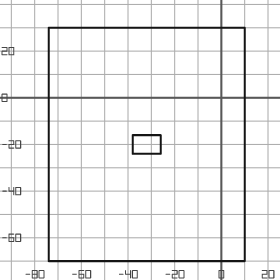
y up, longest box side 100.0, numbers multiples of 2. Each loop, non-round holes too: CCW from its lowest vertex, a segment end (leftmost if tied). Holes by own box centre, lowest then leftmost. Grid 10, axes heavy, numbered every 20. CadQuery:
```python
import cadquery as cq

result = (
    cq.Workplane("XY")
    .moveTo(-74.0, -70.0)
    .lineTo(10.0, -70.0)
    .lineTo(10.0, 30.0)
    .lineTo(-74.0, 30.0)
    .close()
    .moveTo(-38.0, -24.0)
    .lineTo(-26.0, -24.0)
    .lineTo(-26.0, -16.0)
    .lineTo(-38.0, -16.0)
    .close()
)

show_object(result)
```